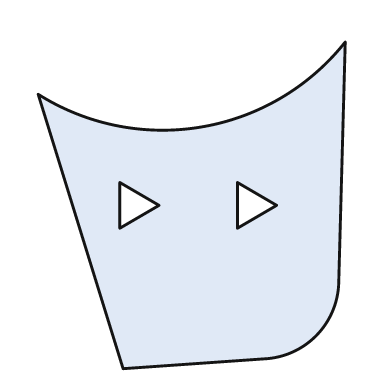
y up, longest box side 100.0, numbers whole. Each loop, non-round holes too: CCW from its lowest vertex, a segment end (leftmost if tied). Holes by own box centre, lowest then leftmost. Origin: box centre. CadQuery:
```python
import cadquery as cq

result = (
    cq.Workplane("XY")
    .moveTo(-21.0, -50.0)
    .lineTo(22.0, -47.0)
    .threePointArc((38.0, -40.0), (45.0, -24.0))
    .lineTo(47.0, 50.0)
    .threePointArc((3.0, 24.0), (-47.0, 34.0))
    .close()
    .moveTo(-22.0, -7.0)
    .lineTo(-10.0, 0.0)
    .lineTo(-22.0, 7.0)
    .close()
    .moveTo(14.0, -7.0)
    .lineTo(26.0, 0.0)
    .lineTo(14.0, 7.0)
    .close()
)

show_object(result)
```